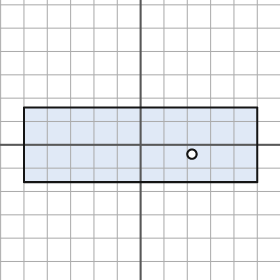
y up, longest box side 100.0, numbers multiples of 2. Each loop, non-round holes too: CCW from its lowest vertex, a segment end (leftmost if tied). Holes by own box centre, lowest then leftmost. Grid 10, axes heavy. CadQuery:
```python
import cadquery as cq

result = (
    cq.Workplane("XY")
    .moveTo(-50.0, -16.0)
    .lineTo(50.0, -16.0)
    .lineTo(50.0, 16.0)
    .lineTo(-50.0, 16.0)
    .close()
    .moveTo(22.0, -4.0)
    .circle(2.0)
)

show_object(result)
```